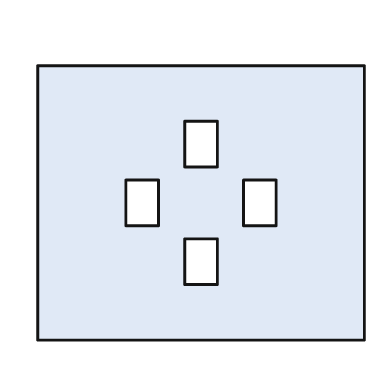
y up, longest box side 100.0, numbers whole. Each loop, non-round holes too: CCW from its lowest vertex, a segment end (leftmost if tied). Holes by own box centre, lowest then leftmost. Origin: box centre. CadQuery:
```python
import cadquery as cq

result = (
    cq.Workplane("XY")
    .moveTo(-50.0, -42.0)
    .lineTo(50.0, -42.0)
    .lineTo(50.0, 42.0)
    .lineTo(-50.0, 42.0)
    .close()
    .moveTo(-5.0, -25.0)
    .lineTo(5.0, -25.0)
    .lineTo(5.0, -11.0)
    .lineTo(-5.0, -11.0)
    .close()
    .moveTo(-23.0, -7.0)
    .lineTo(-13.0, -7.0)
    .lineTo(-13.0, 7.0)
    .lineTo(-23.0, 7.0)
    .close()
    .moveTo(13.0, -7.0)
    .lineTo(23.0, -7.0)
    .lineTo(23.0, 7.0)
    .lineTo(13.0, 7.0)
    .close()
    .moveTo(-5.0, 11.0)
    .lineTo(5.0, 11.0)
    .lineTo(5.0, 25.0)
    .lineTo(-5.0, 25.0)
    .close()
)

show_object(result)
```